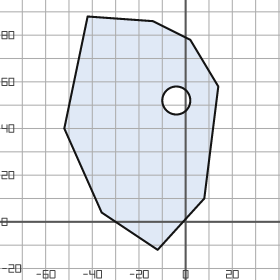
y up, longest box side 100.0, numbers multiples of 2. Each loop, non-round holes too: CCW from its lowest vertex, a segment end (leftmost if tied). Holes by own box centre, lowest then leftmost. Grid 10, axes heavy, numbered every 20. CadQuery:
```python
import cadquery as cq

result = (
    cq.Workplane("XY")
    .moveTo(-12.0, -12.0)
    .lineTo(8.0, 10.0)
    .lineTo(14.0, 58.0)
    .lineTo(2.0, 78.0)
    .lineTo(-14.0, 86.0)
    .lineTo(-42.0, 88.0)
    .lineTo(-52.0, 40.0)
    .lineTo(-36.0, 4.0)
    .close()
    .moveTo(-4.0, 52.0)
    .circle(6.0)
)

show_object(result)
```